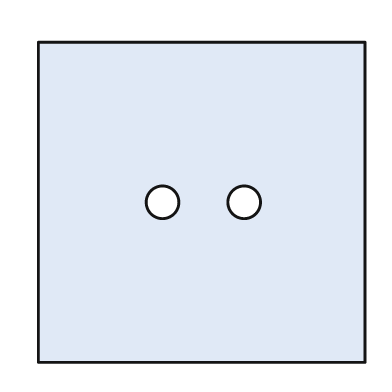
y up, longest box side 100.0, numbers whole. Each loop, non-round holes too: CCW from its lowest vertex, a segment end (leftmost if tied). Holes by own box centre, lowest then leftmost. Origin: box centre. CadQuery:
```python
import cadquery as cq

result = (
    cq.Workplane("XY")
    .moveTo(-50.0, -49.0)
    .lineTo(50.0, -49.0)
    .lineTo(50.0, 49.0)
    .lineTo(-50.0, 49.0)
    .close()
    .moveTo(-12.0, 0.0)
    .circle(5.0)
    .moveTo(13.0, 0.0)
    .circle(5.0)
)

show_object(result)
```